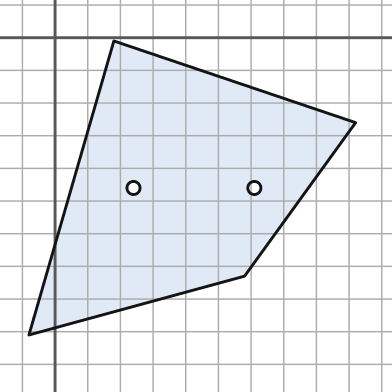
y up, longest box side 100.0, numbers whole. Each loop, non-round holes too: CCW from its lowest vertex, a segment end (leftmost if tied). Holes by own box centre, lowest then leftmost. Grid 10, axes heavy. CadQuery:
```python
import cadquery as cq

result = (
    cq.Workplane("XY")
    .moveTo(-8.0, -91.0)
    .lineTo(58.0, -73.0)
    .lineTo(92.0, -26.0)
    .lineTo(18.0, -1.0)
    .close()
    .moveTo(24.0, -46.0)
    .circle(2.0)
    .moveTo(61.0, -46.0)
    .circle(2.0)
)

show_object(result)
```